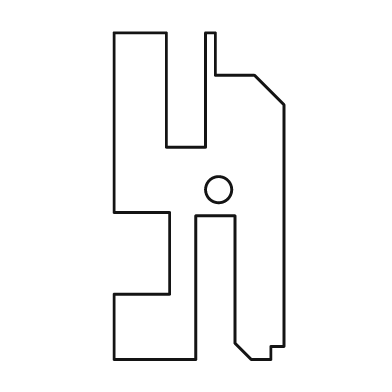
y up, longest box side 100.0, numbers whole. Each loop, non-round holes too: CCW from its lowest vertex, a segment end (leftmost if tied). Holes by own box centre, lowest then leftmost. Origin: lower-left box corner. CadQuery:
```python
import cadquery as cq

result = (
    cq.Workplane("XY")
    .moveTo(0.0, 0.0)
    .lineTo(25.0, 0.0)
    .lineTo(25.0, 44.0)
    .lineTo(37.0, 44.0)
    .lineTo(37.0, 5.0)
    .lineTo(42.0, 0.0)
    .lineTo(48.0, 0.0)
    .lineTo(48.0, 4.0)
    .lineTo(52.0, 4.0)
    .lineTo(52.0, 78.0)
    .lineTo(43.0, 87.0)
    .lineTo(31.0, 87.0)
    .lineTo(31.0, 100.0)
    .lineTo(28.0, 100.0)
    .lineTo(28.0, 65.0)
    .lineTo(16.0, 65.0)
    .lineTo(16.0, 100.0)
    .lineTo(0.0, 100.0)
    .lineTo(0.0, 45.0)
    .lineTo(17.0, 45.0)
    .lineTo(17.0, 20.0)
    .lineTo(0.0, 20.0)
    .close()
    .moveTo(32.0, 52.0)
    .circle(4.0)
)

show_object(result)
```